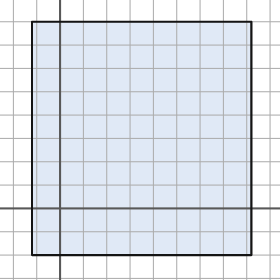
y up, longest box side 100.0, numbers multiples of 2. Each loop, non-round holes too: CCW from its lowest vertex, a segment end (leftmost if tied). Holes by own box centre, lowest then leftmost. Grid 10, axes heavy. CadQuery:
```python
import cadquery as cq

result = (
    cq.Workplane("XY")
    .moveTo(-12.0, -20.0)
    .lineTo(82.0, -20.0)
    .lineTo(82.0, 80.0)
    .lineTo(-12.0, 80.0)
    .close()
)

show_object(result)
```